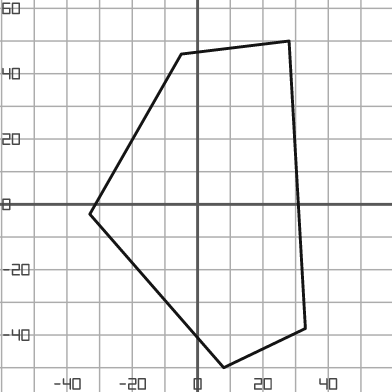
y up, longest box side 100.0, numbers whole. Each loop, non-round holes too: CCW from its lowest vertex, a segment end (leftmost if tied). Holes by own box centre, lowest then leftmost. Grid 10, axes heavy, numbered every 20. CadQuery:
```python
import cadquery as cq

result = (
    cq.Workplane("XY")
    .moveTo(8.0, -50.0)
    .lineTo(33.0, -38.0)
    .lineTo(28.0, 50.0)
    .lineTo(-5.0, 46.0)
    .lineTo(-33.0, -3.0)
    .close()
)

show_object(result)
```